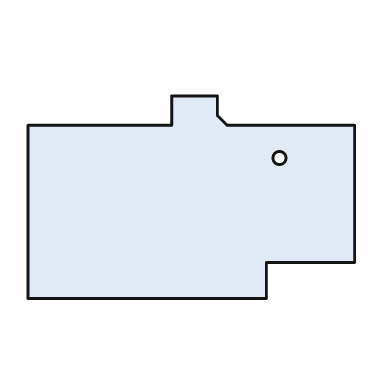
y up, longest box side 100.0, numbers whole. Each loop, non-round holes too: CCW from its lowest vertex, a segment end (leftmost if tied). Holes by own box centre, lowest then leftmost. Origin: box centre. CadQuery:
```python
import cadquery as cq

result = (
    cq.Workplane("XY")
    .moveTo(-50.0, -31.0)
    .lineTo(23.0, -31.0)
    .lineTo(23.0, -20.0)
    .lineTo(50.0, -20.0)
    .lineTo(50.0, 22.0)
    .lineTo(11.0, 22.0)
    .lineTo(8.0, 25.0)
    .lineTo(8.0, 31.0)
    .lineTo(-6.0, 31.0)
    .lineTo(-6.0, 22.0)
    .lineTo(-50.0, 22.0)
    .close()
    .moveTo(27.0, 12.0)
    .circle(2.0)
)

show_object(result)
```